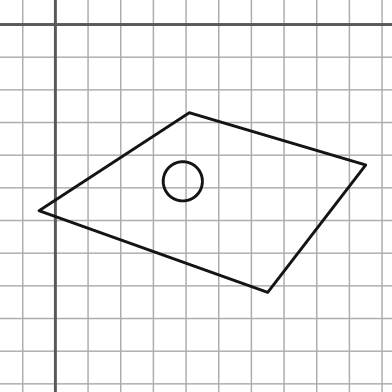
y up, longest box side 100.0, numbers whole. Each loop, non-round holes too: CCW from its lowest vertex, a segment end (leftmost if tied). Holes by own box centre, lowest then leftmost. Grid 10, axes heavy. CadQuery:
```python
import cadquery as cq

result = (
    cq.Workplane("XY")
    .moveTo(65.0, -82.0)
    .lineTo(95.0, -43.0)
    .lineTo(41.0, -27.0)
    .lineTo(-5.0, -57.0)
    .close()
    .moveTo(39.0, -48.0)
    .circle(6.0)
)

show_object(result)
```